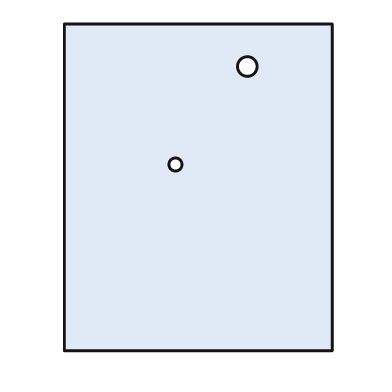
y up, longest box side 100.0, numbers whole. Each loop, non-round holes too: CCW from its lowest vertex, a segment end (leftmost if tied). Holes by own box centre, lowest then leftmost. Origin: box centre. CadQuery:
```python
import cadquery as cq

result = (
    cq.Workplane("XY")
    .moveTo(-41.0, -50.0)
    .lineTo(41.0, -50.0)
    .lineTo(41.0, 50.0)
    .lineTo(-41.0, 50.0)
    .close()
    .moveTo(-7.0, 7.0)
    .circle(2.0)
    .moveTo(15.0, 37.0)
    .circle(3.0)
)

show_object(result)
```